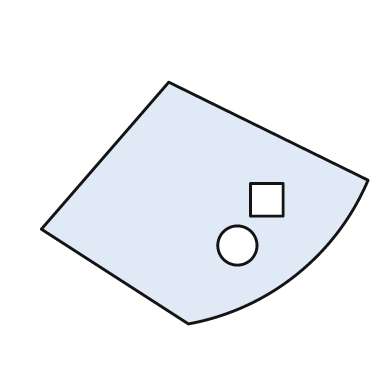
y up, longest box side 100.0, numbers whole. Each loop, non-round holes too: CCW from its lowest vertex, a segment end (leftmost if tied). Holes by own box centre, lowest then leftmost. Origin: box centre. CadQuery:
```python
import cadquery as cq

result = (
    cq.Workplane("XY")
    .moveTo(-5.0, -37.0)
    .threePointArc((28.0, -22.0), (50.0, 7.0))
    .lineTo(-11.0, 37.0)
    .lineTo(-50.0, -8.0)
    .close()
    .moveTo(10.0, -13.0)
    .circle(6.0)
    .moveTo(14.0, -4.0)
    .lineTo(24.0, -4.0)
    .lineTo(24.0, 6.0)
    .lineTo(14.0, 6.0)
    .close()
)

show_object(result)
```